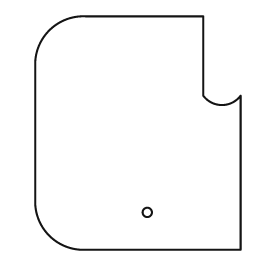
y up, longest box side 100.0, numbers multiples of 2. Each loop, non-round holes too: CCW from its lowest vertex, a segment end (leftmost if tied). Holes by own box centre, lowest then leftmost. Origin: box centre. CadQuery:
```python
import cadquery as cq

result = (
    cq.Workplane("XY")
    .moveTo(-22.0, -50.0)
    .lineTo(44.0, -50.0)
    .lineTo(44.0, 16.0)
    .threePointArc((36.0, 12.0), (28.0, 16.0))
    .lineTo(28.0, 50.0)
    .lineTo(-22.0, 50.0)
    .threePointArc((-38.0, 44.0), (-44.0, 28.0))
    .lineTo(-44.0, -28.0)
    .threePointArc((-38.0, -44.0), (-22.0, -50.0))
    .close()
    .moveTo(4.0, -34.0)
    .circle(2.0)
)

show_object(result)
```